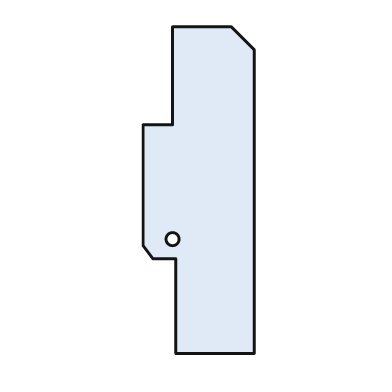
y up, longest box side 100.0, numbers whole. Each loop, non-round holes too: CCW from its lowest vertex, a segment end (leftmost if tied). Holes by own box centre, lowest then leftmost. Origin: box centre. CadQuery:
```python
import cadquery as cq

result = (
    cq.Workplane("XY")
    .moveTo(-7.0, -50.0)
    .lineTo(17.0, -50.0)
    .lineTo(17.0, 43.0)
    .lineTo(10.0, 50.0)
    .lineTo(-8.0, 50.0)
    .lineTo(-8.0, 20.0)
    .lineTo(-17.0, 20.0)
    .lineTo(-17.0, -17.0)
    .lineTo(-14.0, -21.0)
    .lineTo(-7.0, -21.0)
    .close()
    .moveTo(-8.0, -15.0)
    .circle(2.0)
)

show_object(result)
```